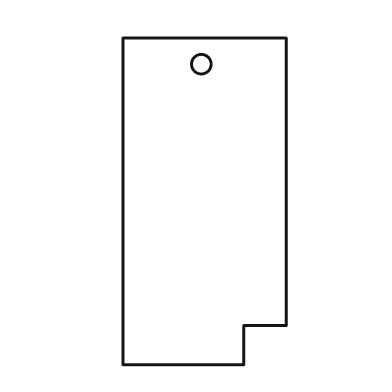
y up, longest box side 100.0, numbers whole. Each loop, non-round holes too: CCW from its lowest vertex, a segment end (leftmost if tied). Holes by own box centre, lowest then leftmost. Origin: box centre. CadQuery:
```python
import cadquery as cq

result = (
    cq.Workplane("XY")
    .moveTo(-25.0, -50.0)
    .lineTo(12.0, -50.0)
    .lineTo(12.0, -38.0)
    .lineTo(25.0, -38.0)
    .lineTo(25.0, 50.0)
    .lineTo(-25.0, 50.0)
    .close()
    .moveTo(-1.0, 42.0)
    .circle(3.0)
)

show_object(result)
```